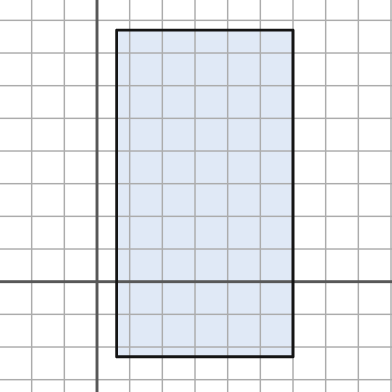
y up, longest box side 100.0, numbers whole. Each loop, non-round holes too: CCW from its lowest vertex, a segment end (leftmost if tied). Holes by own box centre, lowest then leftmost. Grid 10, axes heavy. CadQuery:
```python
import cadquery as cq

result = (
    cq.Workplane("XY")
    .moveTo(6.0, -23.0)
    .lineTo(60.0, -23.0)
    .lineTo(60.0, 77.0)
    .lineTo(6.0, 77.0)
    .close()
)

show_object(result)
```